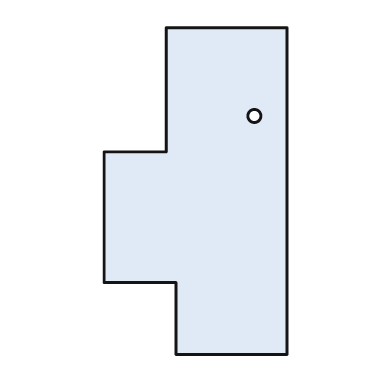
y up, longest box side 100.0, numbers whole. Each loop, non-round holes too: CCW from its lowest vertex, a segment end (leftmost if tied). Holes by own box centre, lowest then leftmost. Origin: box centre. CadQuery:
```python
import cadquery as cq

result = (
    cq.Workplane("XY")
    .moveTo(-6.0, -50.0)
    .lineTo(28.0, -50.0)
    .lineTo(28.0, 50.0)
    .lineTo(-9.0, 50.0)
    .lineTo(-9.0, 12.0)
    .lineTo(-28.0, 12.0)
    .lineTo(-28.0, -28.0)
    .lineTo(-6.0, -28.0)
    .close()
    .moveTo(18.0, 23.0)
    .circle(2.0)
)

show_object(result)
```